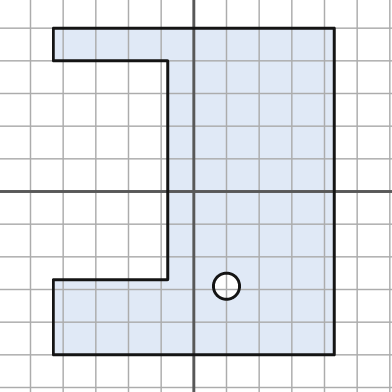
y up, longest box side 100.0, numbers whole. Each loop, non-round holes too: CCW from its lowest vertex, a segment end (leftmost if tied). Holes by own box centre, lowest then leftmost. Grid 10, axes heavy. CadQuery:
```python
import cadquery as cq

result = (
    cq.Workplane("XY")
    .moveTo(-43.0, -50.0)
    .lineTo(43.0, -50.0)
    .lineTo(43.0, 50.0)
    .lineTo(-43.0, 50.0)
    .lineTo(-43.0, 40.0)
    .lineTo(-8.0, 40.0)
    .lineTo(-8.0, -27.0)
    .lineTo(-43.0, -27.0)
    .close()
    .moveTo(10.0, -29.0)
    .circle(4.0)
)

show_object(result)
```